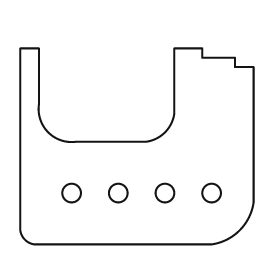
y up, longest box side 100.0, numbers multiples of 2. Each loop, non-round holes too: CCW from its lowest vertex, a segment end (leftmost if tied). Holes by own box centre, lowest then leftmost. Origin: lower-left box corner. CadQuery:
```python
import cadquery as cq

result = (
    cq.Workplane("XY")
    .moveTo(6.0, 0.0)
    .lineTo(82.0, 0.0)
    .threePointArc((94.0, 6.0), (100.0, 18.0))
    .lineTo(100.0, 76.0)
    .lineTo(92.0, 76.0)
    .lineTo(92.0, 80.0)
    .lineTo(78.0, 80.0)
    .lineTo(78.0, 84.0)
    .lineTo(66.0, 84.0)
    .lineTo(66.0, 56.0)
    .threePointArc((62.0, 48.0), (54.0, 44.0))
    .lineTo(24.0, 44.0)
    .threePointArc((12.0, 48.0), (8.0, 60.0))
    .lineTo(8.0, 84.0)
    .lineTo(0.0, 84.0)
    .lineTo(0.0, 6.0)
    .threePointArc((2.0, 2.0), (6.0, 0.0))
    .close()
    .moveTo(22.0, 22.0)
    .circle(4.0)
    .moveTo(42.0, 22.0)
    .circle(4.0)
    .moveTo(62.0, 22.0)
    .circle(4.0)
    .moveTo(82.0, 22.0)
    .circle(4.0)
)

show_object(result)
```